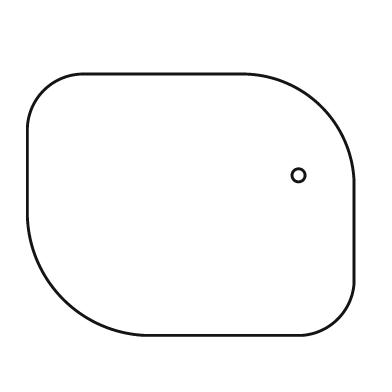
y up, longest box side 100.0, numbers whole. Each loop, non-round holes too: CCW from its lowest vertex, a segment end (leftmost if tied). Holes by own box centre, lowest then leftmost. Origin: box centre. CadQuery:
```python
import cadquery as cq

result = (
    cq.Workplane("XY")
    .moveTo(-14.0, -40.0)
    .lineTo(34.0, -40.0)
    .threePointArc((45.0, -35.0), (50.0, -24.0))
    .lineTo(50.0, 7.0)
    .threePointArc((40.0, 30.0), (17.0, 40.0))
    .lineTo(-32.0, 40.0)
    .threePointArc((-45.0, 35.0), (-50.0, 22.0))
    .lineTo(-50.0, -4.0)
    .threePointArc((-39.0, -29.0), (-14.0, -40.0))
    .close()
    .moveTo(33.0, 9.0)
    .circle(2.0)
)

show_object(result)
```